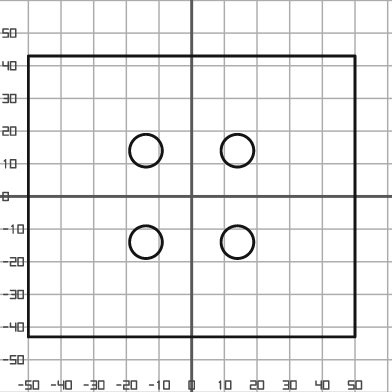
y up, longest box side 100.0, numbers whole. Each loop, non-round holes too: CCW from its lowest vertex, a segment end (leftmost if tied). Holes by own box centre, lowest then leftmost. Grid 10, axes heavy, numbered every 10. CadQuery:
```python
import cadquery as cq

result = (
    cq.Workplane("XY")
    .moveTo(-50.0, -43.0)
    .lineTo(50.0, -43.0)
    .lineTo(50.0, 43.0)
    .lineTo(-50.0, 43.0)
    .close()
    .moveTo(-14.0, -14.0)
    .circle(5.0)
    .moveTo(14.0, -14.0)
    .circle(5.0)
    .moveTo(-14.0, 14.0)
    .circle(5.0)
    .moveTo(14.0, 14.0)
    .circle(5.0)
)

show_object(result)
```